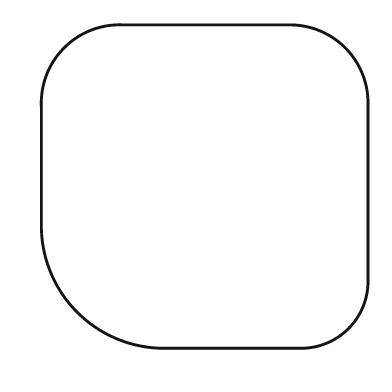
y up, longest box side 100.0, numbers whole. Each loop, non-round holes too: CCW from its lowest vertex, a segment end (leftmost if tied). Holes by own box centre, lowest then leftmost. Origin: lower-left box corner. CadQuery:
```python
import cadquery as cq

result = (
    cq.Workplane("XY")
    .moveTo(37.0, 0.0)
    .lineTo(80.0, 0.0)
    .threePointArc((94.0, 6.0), (100.0, 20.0))
    .lineTo(100.0, 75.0)
    .threePointArc((93.0, 92.0), (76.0, 99.0))
    .lineTo(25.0, 99.0)
    .threePointArc((7.0, 92.0), (0.0, 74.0))
    .lineTo(0.0, 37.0)
    .threePointArc((11.0, 11.0), (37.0, 0.0))
    .close()
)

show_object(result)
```